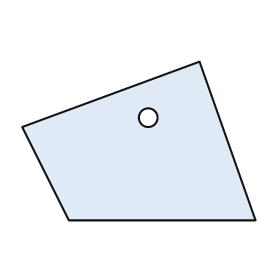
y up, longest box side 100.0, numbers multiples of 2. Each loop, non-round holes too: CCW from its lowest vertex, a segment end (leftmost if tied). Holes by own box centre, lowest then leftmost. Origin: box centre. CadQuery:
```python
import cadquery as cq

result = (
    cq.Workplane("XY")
    .moveTo(-30.0, -34.0)
    .lineTo(50.0, -34.0)
    .lineTo(26.0, 34.0)
    .lineTo(-50.0, 6.0)
    .close()
    .moveTo(4.0, 10.0)
    .circle(4.0)
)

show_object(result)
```